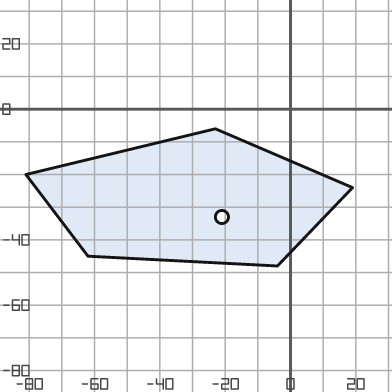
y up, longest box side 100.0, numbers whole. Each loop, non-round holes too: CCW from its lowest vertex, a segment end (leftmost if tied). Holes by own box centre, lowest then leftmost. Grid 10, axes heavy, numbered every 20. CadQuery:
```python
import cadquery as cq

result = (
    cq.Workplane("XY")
    .moveTo(-4.0, -48.0)
    .lineTo(19.0, -24.0)
    .lineTo(-23.0, -6.0)
    .lineTo(-81.0, -20.0)
    .lineTo(-62.0, -45.0)
    .close()
    .moveTo(-21.0, -33.0)
    .circle(2.0)
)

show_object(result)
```